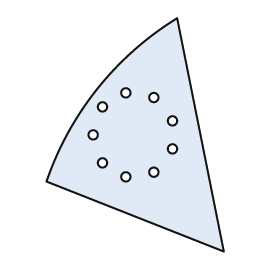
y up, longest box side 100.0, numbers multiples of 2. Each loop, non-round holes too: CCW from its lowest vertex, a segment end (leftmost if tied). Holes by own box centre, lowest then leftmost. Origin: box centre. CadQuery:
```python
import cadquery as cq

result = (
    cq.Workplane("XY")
    .moveTo(38.0, -50.0)
    .lineTo(18.0, 50.0)
    .threePointArc((-16.0, 20.0), (-38.0, -20.0))
    .close()
    .moveTo(-4.0, -18.0)
    .circle(2.0)
    .moveTo(8.0, -16.0)
    .circle(2.0)
    .moveTo(-14.0, -12.0)
    .circle(2.0)
    .moveTo(16.0, -6.0)
    .circle(2.0)
    .moveTo(-18.0, 0.0)
    .circle(2.0)
    .moveTo(16.0, 6.0)
    .circle(2.0)
    .moveTo(-14.0, 12.0)
    .circle(2.0)
    .moveTo(8.0, 16.0)
    .circle(2.0)
    .moveTo(-4.0, 18.0)
    .circle(2.0)
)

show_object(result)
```